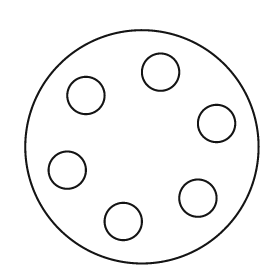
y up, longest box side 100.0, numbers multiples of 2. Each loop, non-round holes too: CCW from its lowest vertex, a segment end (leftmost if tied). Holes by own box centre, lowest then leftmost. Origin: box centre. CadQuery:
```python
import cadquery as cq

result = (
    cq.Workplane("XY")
    .moveTo(0.0, 0.0)
    .circle(50.0)
    .moveTo(-8.0, -32.0)
    .circle(8.0)
    .moveTo(24.0, -22.0)
    .circle(8.0)
    .moveTo(-32.0, -10.0)
    .circle(8.0)
    .moveTo(32.0, 10.0)
    .circle(8.0)
    .moveTo(-24.0, 22.0)
    .circle(8.0)
    .moveTo(8.0, 32.0)
    .circle(8.0)
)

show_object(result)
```